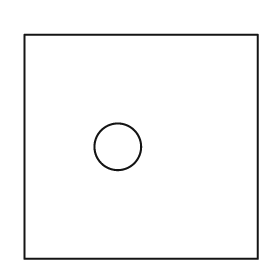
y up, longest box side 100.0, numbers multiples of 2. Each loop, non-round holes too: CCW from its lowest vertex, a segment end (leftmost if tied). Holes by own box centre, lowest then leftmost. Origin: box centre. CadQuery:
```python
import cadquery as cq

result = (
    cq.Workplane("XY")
    .moveTo(-50.0, -48.0)
    .lineTo(50.0, -48.0)
    .lineTo(50.0, 48.0)
    .lineTo(-50.0, 48.0)
    .close()
    .moveTo(-10.0, 0.0)
    .circle(10.0)
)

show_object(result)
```